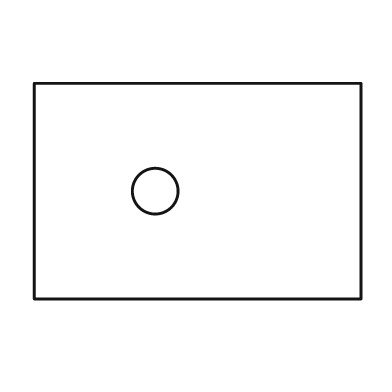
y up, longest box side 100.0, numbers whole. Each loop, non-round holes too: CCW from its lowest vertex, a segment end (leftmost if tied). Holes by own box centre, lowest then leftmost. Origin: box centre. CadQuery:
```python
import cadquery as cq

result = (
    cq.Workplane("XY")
    .moveTo(-50.0, -33.0)
    .lineTo(50.0, -33.0)
    .lineTo(50.0, 33.0)
    .lineTo(-50.0, 33.0)
    .close()
    .moveTo(-13.0, 0.0)
    .circle(7.0)
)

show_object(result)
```